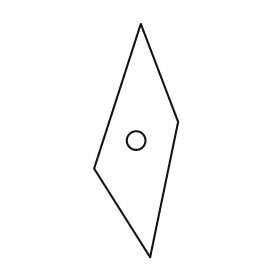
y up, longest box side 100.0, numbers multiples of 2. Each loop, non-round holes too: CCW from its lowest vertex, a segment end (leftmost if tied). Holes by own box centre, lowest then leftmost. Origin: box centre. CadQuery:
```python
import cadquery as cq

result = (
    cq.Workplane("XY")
    .moveTo(6.0, -50.0)
    .lineTo(18.0, 8.0)
    .lineTo(2.0, 50.0)
    .lineTo(-18.0, -12.0)
    .close()
    .moveTo(0.0, 0.0)
    .circle(4.0)
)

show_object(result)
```